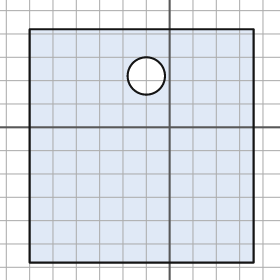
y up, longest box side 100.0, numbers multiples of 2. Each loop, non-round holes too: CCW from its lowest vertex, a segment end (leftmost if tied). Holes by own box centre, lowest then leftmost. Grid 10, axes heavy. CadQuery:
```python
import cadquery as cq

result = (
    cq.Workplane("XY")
    .moveTo(-60.0, -58.0)
    .lineTo(36.0, -58.0)
    .lineTo(36.0, 42.0)
    .lineTo(-60.0, 42.0)
    .close()
    .moveTo(-10.0, 22.0)
    .circle(8.0)
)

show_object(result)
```